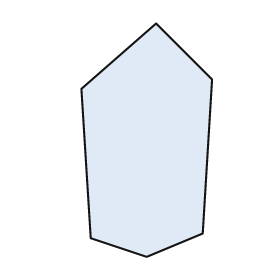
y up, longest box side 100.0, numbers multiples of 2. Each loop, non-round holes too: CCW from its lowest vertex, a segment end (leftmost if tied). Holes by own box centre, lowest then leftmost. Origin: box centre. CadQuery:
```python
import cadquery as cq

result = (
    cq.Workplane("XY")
    .moveTo(0.0, -50.0)
    .lineTo(24.0, -40.0)
    .lineTo(28.0, 26.0)
    .lineTo(4.0, 50.0)
    .lineTo(-28.0, 22.0)
    .lineTo(-24.0, -42.0)
    .close()
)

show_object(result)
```